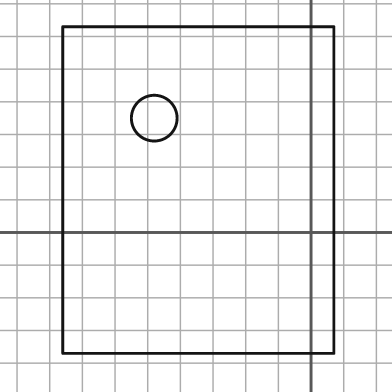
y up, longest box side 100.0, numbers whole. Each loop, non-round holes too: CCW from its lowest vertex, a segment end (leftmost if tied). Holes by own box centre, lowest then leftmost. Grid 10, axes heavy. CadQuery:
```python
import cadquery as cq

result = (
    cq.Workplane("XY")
    .moveTo(-76.0, -37.0)
    .lineTo(7.0, -37.0)
    .lineTo(7.0, 63.0)
    .lineTo(-76.0, 63.0)
    .close()
    .moveTo(-48.0, 35.0)
    .circle(7.0)
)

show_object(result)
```